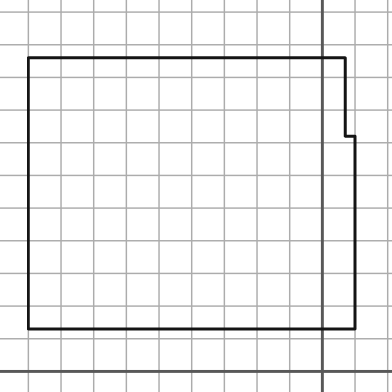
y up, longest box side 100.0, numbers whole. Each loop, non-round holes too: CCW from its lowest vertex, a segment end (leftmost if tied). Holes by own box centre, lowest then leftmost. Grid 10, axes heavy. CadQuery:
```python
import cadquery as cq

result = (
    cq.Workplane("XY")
    .moveTo(-90.0, 13.0)
    .lineTo(10.0, 13.0)
    .lineTo(10.0, 72.0)
    .lineTo(7.0, 72.0)
    .lineTo(7.0, 96.0)
    .lineTo(-90.0, 96.0)
    .close()
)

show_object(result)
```